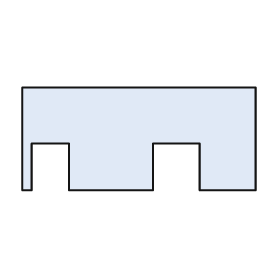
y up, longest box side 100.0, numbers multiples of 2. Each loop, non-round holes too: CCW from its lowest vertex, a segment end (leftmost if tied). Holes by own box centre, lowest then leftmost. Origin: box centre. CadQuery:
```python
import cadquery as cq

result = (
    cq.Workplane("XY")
    .moveTo(-50.0, -22.0)
    .lineTo(-46.0, -22.0)
    .lineTo(-46.0, -2.0)
    .lineTo(-30.0, -2.0)
    .lineTo(-30.0, -22.0)
    .lineTo(6.0, -22.0)
    .lineTo(6.0, -2.0)
    .lineTo(26.0, -2.0)
    .lineTo(26.0, -22.0)
    .lineTo(50.0, -22.0)
    .lineTo(50.0, 22.0)
    .lineTo(-50.0, 22.0)
    .close()
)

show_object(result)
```